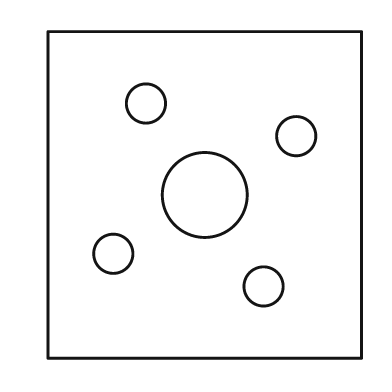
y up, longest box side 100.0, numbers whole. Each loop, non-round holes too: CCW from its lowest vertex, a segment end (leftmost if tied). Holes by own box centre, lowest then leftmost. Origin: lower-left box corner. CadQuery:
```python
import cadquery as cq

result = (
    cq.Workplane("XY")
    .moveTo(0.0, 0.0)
    .lineTo(96.0, 0.0)
    .lineTo(96.0, 100.0)
    .lineTo(0.0, 100.0)
    .close()
    .moveTo(66.0, 22.0)
    .circle(6.0)
    .moveTo(20.0, 32.0)
    .circle(6.0)
    .moveTo(48.0, 50.0)
    .circle(13.0)
    .moveTo(76.0, 68.0)
    .circle(6.0)
    .moveTo(30.0, 78.0)
    .circle(6.0)
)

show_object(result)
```